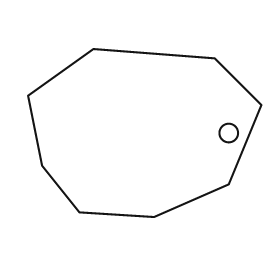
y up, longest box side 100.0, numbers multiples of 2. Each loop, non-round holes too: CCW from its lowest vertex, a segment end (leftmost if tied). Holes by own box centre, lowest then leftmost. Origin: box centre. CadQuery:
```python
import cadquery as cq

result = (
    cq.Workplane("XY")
    .moveTo(4.0, -36.0)
    .lineTo(36.0, -22.0)
    .lineTo(50.0, 12.0)
    .lineTo(30.0, 32.0)
    .lineTo(-22.0, 36.0)
    .lineTo(-50.0, 16.0)
    .lineTo(-44.0, -14.0)
    .lineTo(-28.0, -34.0)
    .close()
    .moveTo(36.0, 0.0)
    .circle(4.0)
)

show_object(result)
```